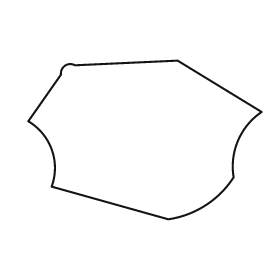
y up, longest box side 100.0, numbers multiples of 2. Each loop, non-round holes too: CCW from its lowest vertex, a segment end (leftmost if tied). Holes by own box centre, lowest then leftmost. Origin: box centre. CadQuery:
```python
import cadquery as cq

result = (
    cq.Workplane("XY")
    .moveTo(10.0, -34.0)
    .threePointArc((26.0, -28.0), (38.0, -16.0))
    .threePointArc((40.0, 0.0), (50.0, 12.0))
    .lineTo(14.0, 34.0)
    .lineTo(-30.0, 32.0)
    .threePointArc((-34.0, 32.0), (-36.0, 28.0))
    .lineTo(-50.0, 8.0)
    .threePointArc((-40.0, -4.0), (-40.0, -20.0))
    .close()
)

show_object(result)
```